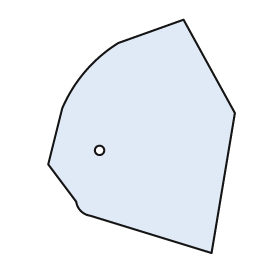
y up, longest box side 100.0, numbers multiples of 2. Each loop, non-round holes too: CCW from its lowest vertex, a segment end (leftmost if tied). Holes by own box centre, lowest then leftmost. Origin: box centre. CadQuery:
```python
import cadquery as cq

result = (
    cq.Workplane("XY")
    .moveTo(30.0, -50.0)
    .lineTo(40.0, 10.0)
    .lineTo(18.0, 50.0)
    .lineTo(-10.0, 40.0)
    .threePointArc((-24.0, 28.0), (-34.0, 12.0))
    .lineTo(-40.0, -12.0)
    .lineTo(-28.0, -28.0)
    .threePointArc((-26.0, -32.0), (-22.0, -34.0))
    .close()
    .moveTo(-18.0, -6.0)
    .circle(2.0)
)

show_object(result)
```